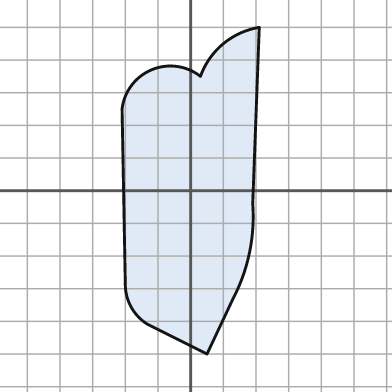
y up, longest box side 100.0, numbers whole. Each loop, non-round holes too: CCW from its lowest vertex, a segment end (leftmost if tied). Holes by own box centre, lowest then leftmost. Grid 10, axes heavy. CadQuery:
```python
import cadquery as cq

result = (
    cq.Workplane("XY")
    .moveTo(5.0, -50.0)
    .lineTo(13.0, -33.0)
    .threePointArc((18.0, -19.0), (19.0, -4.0))
    .lineTo(21.0, 50.0)
    .threePointArc((10.0, 45.0), (3.0, 35.0))
    .threePointArc((-12.0, 37.0), (-21.0, 25.0))
    .lineTo(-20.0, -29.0)
    .threePointArc((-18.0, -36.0), (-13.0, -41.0))
    .close()
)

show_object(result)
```